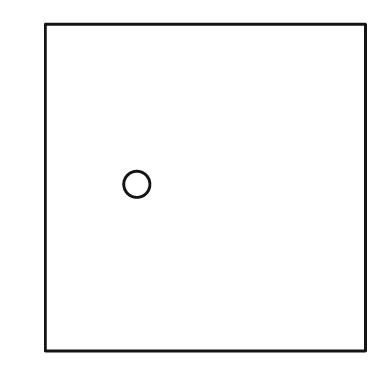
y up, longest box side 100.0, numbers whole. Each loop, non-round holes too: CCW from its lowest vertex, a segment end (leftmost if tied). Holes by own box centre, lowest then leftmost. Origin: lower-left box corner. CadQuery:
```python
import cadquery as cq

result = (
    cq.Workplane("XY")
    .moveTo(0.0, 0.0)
    .lineTo(98.0, 0.0)
    .lineTo(98.0, 100.0)
    .lineTo(0.0, 100.0)
    .close()
    .moveTo(28.0, 51.0)
    .circle(4.0)
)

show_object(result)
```